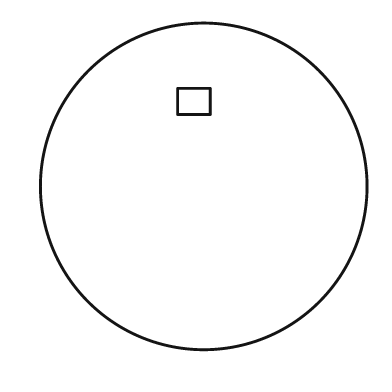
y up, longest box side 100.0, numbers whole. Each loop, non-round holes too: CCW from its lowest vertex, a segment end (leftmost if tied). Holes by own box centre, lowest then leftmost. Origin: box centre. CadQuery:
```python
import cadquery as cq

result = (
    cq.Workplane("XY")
    .moveTo(0.0, 0.0)
    .circle(50.0)
    .moveTo(-8.0, 22.0)
    .lineTo(2.0, 22.0)
    .lineTo(2.0, 30.0)
    .lineTo(-8.0, 30.0)
    .close()
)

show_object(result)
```